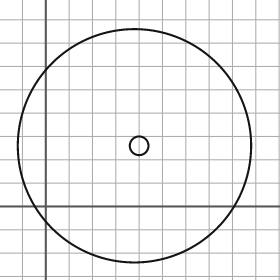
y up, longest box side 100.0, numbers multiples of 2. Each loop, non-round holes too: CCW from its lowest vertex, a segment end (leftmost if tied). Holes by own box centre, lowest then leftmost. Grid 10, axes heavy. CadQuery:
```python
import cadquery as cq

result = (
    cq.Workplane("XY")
    .moveTo(38.0, 26.0)
    .circle(50.0)
    .moveTo(40.0, 26.0)
    .circle(4.0)
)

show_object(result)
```